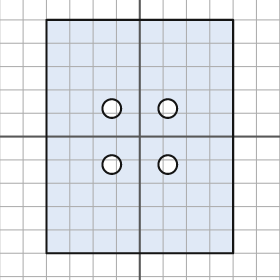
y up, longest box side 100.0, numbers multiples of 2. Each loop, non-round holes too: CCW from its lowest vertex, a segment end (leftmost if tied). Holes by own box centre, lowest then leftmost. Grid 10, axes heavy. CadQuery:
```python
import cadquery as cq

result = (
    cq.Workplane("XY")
    .moveTo(-40.0, -50.0)
    .lineTo(40.0, -50.0)
    .lineTo(40.0, 50.0)
    .lineTo(-40.0, 50.0)
    .close()
    .moveTo(-12.0, -12.0)
    .circle(4.0)
    .moveTo(12.0, -12.0)
    .circle(4.0)
    .moveTo(-12.0, 12.0)
    .circle(4.0)
    .moveTo(12.0, 12.0)
    .circle(4.0)
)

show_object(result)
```